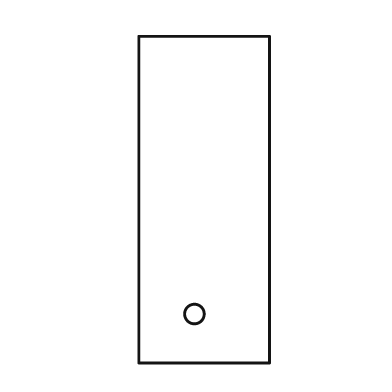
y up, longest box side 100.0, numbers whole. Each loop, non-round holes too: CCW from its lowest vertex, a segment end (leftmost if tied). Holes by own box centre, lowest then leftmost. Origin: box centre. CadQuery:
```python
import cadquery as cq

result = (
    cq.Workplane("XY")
    .moveTo(-20.0, -50.0)
    .lineTo(20.0, -50.0)
    .lineTo(20.0, 50.0)
    .lineTo(-20.0, 50.0)
    .close()
    .moveTo(-3.0, -35.0)
    .circle(3.0)
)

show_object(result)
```